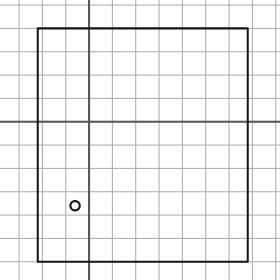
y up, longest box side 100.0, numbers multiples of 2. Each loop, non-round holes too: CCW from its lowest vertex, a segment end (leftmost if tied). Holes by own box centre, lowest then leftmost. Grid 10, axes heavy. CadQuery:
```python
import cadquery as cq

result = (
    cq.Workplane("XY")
    .moveTo(-22.0, -60.0)
    .lineTo(68.0, -60.0)
    .lineTo(68.0, 40.0)
    .lineTo(-22.0, 40.0)
    .close()
    .moveTo(-6.0, -36.0)
    .circle(2.0)
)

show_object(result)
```